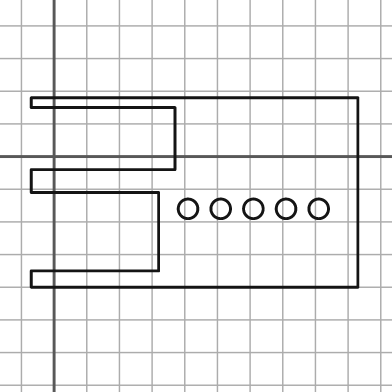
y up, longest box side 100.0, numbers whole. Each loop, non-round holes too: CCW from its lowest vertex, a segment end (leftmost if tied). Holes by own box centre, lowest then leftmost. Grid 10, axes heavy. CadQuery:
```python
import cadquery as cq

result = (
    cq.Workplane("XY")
    .moveTo(-7.0, -40.0)
    .lineTo(93.0, -40.0)
    .lineTo(93.0, 18.0)
    .lineTo(-7.0, 18.0)
    .lineTo(-7.0, 15.0)
    .lineTo(37.0, 15.0)
    .lineTo(37.0, -4.0)
    .lineTo(-7.0, -4.0)
    .lineTo(-7.0, -11.0)
    .lineTo(32.0, -11.0)
    .lineTo(32.0, -35.0)
    .lineTo(-7.0, -35.0)
    .close()
    .moveTo(41.0, -16.0)
    .circle(3.0)
    .moveTo(51.0, -16.0)
    .circle(3.0)
    .moveTo(61.0, -16.0)
    .circle(3.0)
    .moveTo(71.0, -16.0)
    .circle(3.0)
    .moveTo(81.0, -16.0)
    .circle(3.0)
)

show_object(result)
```